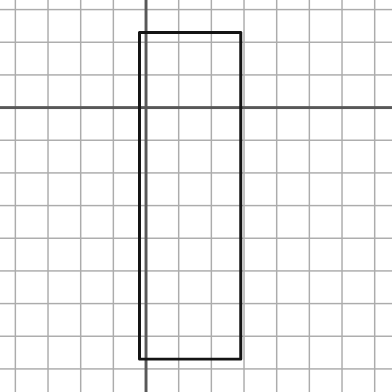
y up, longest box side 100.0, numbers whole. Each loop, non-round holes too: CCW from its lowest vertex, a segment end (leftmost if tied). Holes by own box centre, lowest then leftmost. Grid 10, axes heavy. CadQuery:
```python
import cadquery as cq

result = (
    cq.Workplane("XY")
    .moveTo(-2.0, -77.0)
    .lineTo(29.0, -77.0)
    .lineTo(29.0, 23.0)
    .lineTo(-2.0, 23.0)
    .close()
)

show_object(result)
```